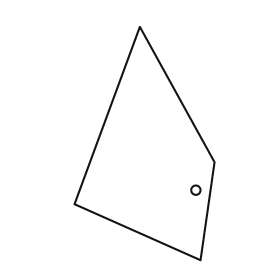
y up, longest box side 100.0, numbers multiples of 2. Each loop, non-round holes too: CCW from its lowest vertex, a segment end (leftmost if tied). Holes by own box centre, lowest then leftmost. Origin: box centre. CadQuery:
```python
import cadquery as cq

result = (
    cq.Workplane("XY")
    .moveTo(24.0, -50.0)
    .lineTo(30.0, -8.0)
    .lineTo(-2.0, 50.0)
    .lineTo(-30.0, -26.0)
    .close()
    .moveTo(22.0, -20.0)
    .circle(2.0)
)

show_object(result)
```